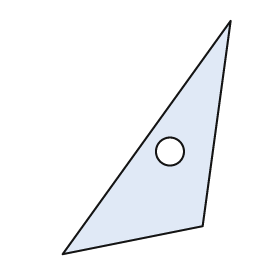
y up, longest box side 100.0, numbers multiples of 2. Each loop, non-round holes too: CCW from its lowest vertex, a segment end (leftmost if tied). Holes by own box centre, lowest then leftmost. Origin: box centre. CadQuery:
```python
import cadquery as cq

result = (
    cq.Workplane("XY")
    .moveTo(-36.0, -50.0)
    .lineTo(24.0, -38.0)
    .lineTo(36.0, 50.0)
    .close()
    .moveTo(10.0, -6.0)
    .circle(6.0)
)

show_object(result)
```